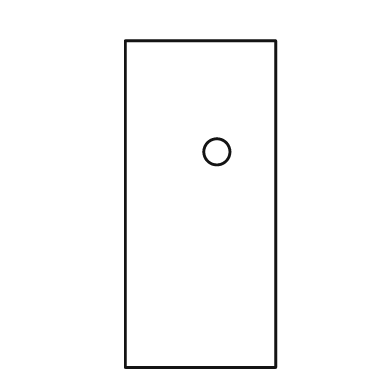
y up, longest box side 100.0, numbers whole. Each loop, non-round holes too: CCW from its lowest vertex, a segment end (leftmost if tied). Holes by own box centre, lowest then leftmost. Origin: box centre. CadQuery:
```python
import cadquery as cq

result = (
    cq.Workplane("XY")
    .moveTo(-23.0, -50.0)
    .lineTo(23.0, -50.0)
    .lineTo(23.0, 50.0)
    .lineTo(-23.0, 50.0)
    .close()
    .moveTo(5.0, 16.0)
    .circle(4.0)
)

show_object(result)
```